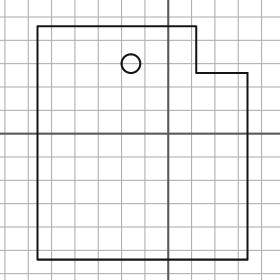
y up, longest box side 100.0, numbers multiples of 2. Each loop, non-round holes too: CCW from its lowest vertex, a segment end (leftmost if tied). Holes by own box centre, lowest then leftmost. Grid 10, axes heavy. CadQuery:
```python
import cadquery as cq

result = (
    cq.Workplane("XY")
    .moveTo(-56.0, -54.0)
    .lineTo(34.0, -54.0)
    .lineTo(34.0, 26.0)
    .lineTo(12.0, 26.0)
    .lineTo(12.0, 46.0)
    .lineTo(-56.0, 46.0)
    .close()
    .moveTo(-16.0, 30.0)
    .circle(4.0)
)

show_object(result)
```